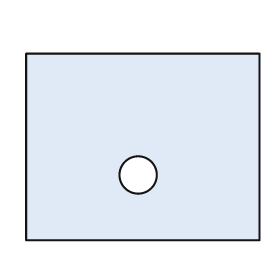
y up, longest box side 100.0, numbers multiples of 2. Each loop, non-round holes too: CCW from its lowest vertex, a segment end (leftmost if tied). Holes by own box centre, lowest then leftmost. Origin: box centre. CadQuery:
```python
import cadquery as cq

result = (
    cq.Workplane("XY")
    .moveTo(-50.0, -40.0)
    .lineTo(50.0, -40.0)
    .lineTo(50.0, 40.0)
    .lineTo(-50.0, 40.0)
    .close()
    .moveTo(-2.0, -12.0)
    .circle(8.0)
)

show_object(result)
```